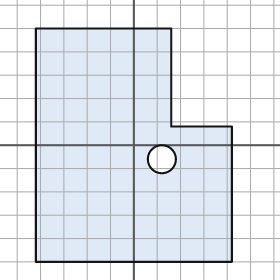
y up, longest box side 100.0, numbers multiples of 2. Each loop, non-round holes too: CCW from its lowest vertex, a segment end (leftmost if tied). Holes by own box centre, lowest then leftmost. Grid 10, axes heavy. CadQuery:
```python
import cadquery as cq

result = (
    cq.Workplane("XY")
    .moveTo(-42.0, -50.0)
    .lineTo(42.0, -50.0)
    .lineTo(42.0, 8.0)
    .lineTo(16.0, 8.0)
    .lineTo(16.0, 50.0)
    .lineTo(-42.0, 50.0)
    .close()
    .moveTo(12.0, -6.0)
    .circle(6.0)
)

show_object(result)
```